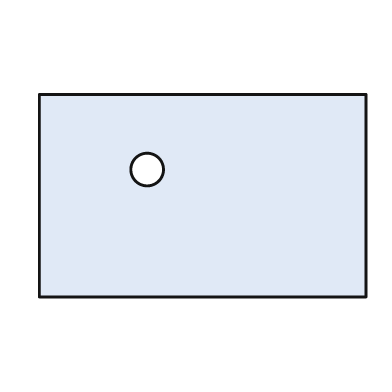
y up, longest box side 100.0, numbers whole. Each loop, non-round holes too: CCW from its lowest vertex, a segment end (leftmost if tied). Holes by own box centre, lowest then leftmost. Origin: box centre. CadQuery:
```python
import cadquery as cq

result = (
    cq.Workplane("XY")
    .moveTo(-50.0, -31.0)
    .lineTo(50.0, -31.0)
    .lineTo(50.0, 31.0)
    .lineTo(-50.0, 31.0)
    .close()
    .moveTo(-17.0, 8.0)
    .circle(5.0)
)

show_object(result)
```